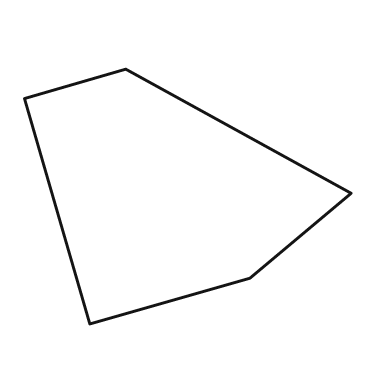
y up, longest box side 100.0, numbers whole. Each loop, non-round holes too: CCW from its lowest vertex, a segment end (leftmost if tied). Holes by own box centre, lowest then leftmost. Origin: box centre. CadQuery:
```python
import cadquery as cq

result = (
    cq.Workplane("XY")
    .moveTo(-30.0, -39.0)
    .lineTo(19.0, -25.0)
    .lineTo(50.0, 1.0)
    .lineTo(-19.0, 39.0)
    .lineTo(-50.0, 30.0)
    .close()
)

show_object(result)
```